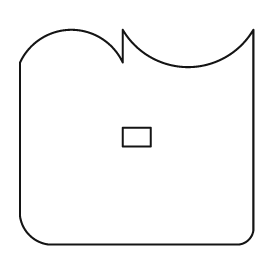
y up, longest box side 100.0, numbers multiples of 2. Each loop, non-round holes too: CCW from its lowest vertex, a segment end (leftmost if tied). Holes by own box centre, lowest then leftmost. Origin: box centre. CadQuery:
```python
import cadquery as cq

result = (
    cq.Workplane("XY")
    .moveTo(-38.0, -46.0)
    .lineTo(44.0, -46.0)
    .threePointArc((48.0, -44.0), (50.0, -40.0))
    .lineTo(50.0, 46.0)
    .threePointArc((22.0, 30.0), (-6.0, 46.0))
    .lineTo(-6.0, 32.0)
    .threePointArc((-28.0, 46.0), (-50.0, 32.0))
    .lineTo(-50.0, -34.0)
    .threePointArc((-46.0, -42.0), (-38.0, -46.0))
    .close()
    .moveTo(-6.0, -4.0)
    .lineTo(6.0, -4.0)
    .lineTo(6.0, 4.0)
    .lineTo(-6.0, 4.0)
    .close()
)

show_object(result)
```